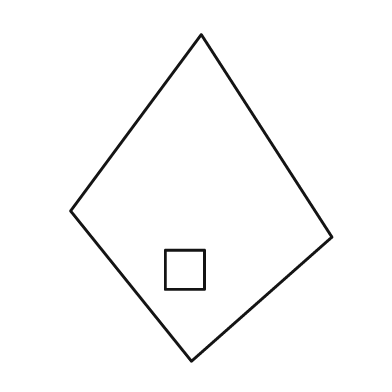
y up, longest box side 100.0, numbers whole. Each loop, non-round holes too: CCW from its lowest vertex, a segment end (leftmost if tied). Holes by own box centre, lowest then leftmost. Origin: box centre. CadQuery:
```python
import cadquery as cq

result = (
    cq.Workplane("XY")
    .moveTo(-3.0, -50.0)
    .lineTo(40.0, -12.0)
    .lineTo(0.0, 50.0)
    .lineTo(-40.0, -4.0)
    .close()
    .moveTo(-11.0, -28.0)
    .lineTo(1.0, -28.0)
    .lineTo(1.0, -16.0)
    .lineTo(-11.0, -16.0)
    .close()
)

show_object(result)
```